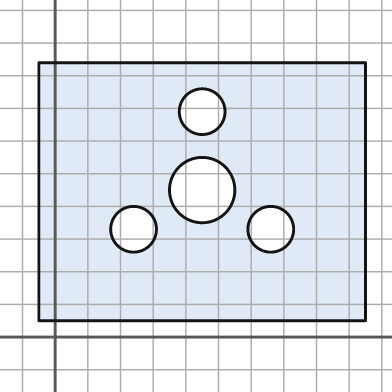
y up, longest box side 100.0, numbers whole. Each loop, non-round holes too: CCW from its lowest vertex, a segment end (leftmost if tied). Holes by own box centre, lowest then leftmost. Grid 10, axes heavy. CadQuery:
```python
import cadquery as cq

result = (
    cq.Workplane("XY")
    .moveTo(-5.0, 5.0)
    .lineTo(95.0, 5.0)
    .lineTo(95.0, 84.0)
    .lineTo(-5.0, 84.0)
    .close()
    .moveTo(24.0, 33.0)
    .circle(7.0)
    .moveTo(66.0, 33.0)
    .circle(7.0)
    .moveTo(45.0, 45.0)
    .circle(10.0)
    .moveTo(45.0, 69.0)
    .circle(7.0)
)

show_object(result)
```